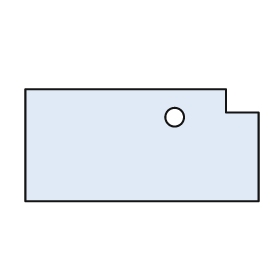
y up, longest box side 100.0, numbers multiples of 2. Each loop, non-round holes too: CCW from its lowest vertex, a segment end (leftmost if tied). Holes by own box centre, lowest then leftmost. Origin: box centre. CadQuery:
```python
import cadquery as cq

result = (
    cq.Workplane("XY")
    .moveTo(-50.0, -24.0)
    .lineTo(50.0, -24.0)
    .lineTo(50.0, 14.0)
    .lineTo(36.0, 14.0)
    .lineTo(36.0, 24.0)
    .lineTo(-50.0, 24.0)
    .close()
    .moveTo(14.0, 12.0)
    .circle(4.0)
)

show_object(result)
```